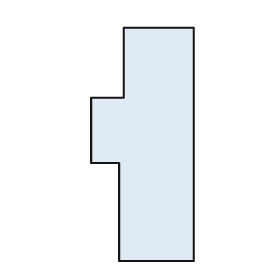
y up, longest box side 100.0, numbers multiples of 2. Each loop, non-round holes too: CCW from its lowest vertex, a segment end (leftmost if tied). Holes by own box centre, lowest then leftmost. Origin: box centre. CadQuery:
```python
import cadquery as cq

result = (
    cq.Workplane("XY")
    .moveTo(-10.0, -50.0)
    .lineTo(22.0, -50.0)
    .lineTo(22.0, 50.0)
    .lineTo(-8.0, 50.0)
    .lineTo(-8.0, 20.0)
    .lineTo(-22.0, 20.0)
    .lineTo(-22.0, -8.0)
    .lineTo(-10.0, -8.0)
    .close()
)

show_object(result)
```